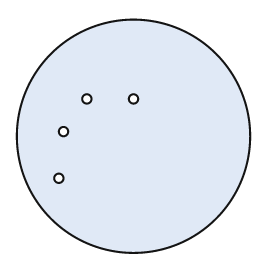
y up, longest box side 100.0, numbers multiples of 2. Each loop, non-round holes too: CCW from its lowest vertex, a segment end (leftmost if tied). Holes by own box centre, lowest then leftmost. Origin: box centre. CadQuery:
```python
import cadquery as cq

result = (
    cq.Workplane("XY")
    .moveTo(0.0, 0.0)
    .circle(50.0)
    .moveTo(-32.0, -18.0)
    .circle(2.0)
    .moveTo(-30.0, 2.0)
    .circle(2.0)
    .moveTo(-20.0, 16.0)
    .circle(2.0)
    .moveTo(0.0, 16.0)
    .circle(2.0)
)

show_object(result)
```